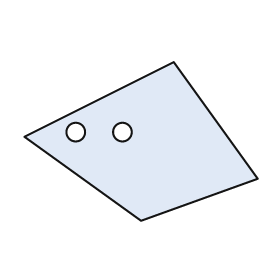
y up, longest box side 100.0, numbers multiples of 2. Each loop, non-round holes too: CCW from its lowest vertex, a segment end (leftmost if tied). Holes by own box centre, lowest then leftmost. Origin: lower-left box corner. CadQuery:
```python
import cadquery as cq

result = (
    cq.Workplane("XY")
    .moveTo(50.0, 0.0)
    .lineTo(100.0, 18.0)
    .lineTo(64.0, 68.0)
    .lineTo(0.0, 36.0)
    .close()
    .moveTo(22.0, 38.0)
    .circle(4.0)
    .moveTo(42.0, 38.0)
    .circle(4.0)
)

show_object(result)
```